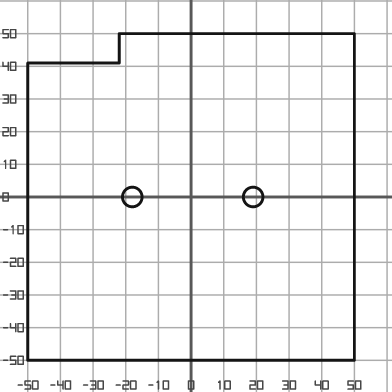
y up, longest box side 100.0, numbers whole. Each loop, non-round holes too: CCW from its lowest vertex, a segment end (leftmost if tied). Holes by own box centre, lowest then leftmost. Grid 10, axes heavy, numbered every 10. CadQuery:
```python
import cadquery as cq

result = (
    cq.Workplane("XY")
    .moveTo(-50.0, -50.0)
    .lineTo(50.0, -50.0)
    .lineTo(50.0, 50.0)
    .lineTo(-22.0, 50.0)
    .lineTo(-22.0, 41.0)
    .lineTo(-50.0, 41.0)
    .close()
    .moveTo(-18.0, 0.0)
    .circle(3.0)
    .moveTo(19.0, 0.0)
    .circle(3.0)
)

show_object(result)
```